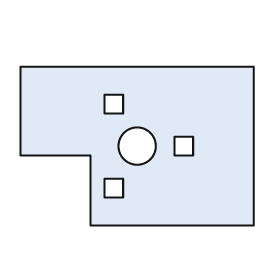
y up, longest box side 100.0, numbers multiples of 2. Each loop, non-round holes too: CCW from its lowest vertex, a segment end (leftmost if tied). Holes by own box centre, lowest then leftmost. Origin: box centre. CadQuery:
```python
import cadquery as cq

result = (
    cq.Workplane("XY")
    .moveTo(-20.0, -34.0)
    .lineTo(50.0, -34.0)
    .lineTo(50.0, 34.0)
    .lineTo(-50.0, 34.0)
    .lineTo(-50.0, -4.0)
    .lineTo(-20.0, -4.0)
    .close()
    .moveTo(-14.0, -22.0)
    .lineTo(-6.0, -22.0)
    .lineTo(-6.0, -14.0)
    .lineTo(-14.0, -14.0)
    .close()
    .moveTo(0.0, 0.0)
    .circle(8.0)
    .moveTo(16.0, -4.0)
    .lineTo(24.0, -4.0)
    .lineTo(24.0, 4.0)
    .lineTo(16.0, 4.0)
    .close()
    .moveTo(-14.0, 14.0)
    .lineTo(-6.0, 14.0)
    .lineTo(-6.0, 22.0)
    .lineTo(-14.0, 22.0)
    .close()
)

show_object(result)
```